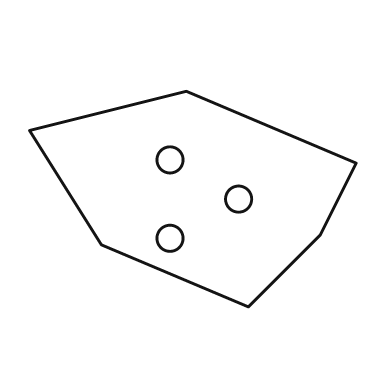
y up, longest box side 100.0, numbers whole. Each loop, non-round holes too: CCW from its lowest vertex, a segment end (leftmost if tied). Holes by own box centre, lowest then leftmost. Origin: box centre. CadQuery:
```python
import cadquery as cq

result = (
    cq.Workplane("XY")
    .moveTo(17.0, -33.0)
    .lineTo(39.0, -11.0)
    .lineTo(50.0, 11.0)
    .lineTo(-2.0, 33.0)
    .lineTo(-50.0, 21.0)
    .lineTo(-28.0, -14.0)
    .close()
    .moveTo(-7.0, -12.0)
    .circle(4.0)
    .moveTo(14.0, 0.0)
    .circle(4.0)
    .moveTo(-7.0, 12.0)
    .circle(4.0)
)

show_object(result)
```